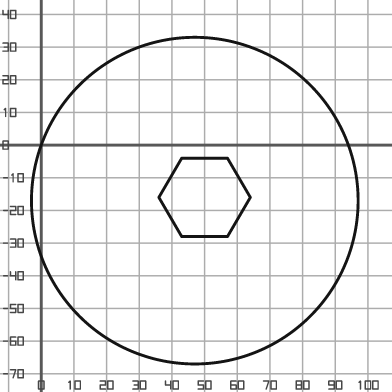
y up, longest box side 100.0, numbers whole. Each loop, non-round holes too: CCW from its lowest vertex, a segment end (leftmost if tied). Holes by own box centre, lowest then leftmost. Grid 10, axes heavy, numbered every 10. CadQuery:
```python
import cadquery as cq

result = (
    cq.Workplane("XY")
    .moveTo(47.0, -17.0)
    .circle(50.0)
    .moveTo(43.0, -28.0)
    .lineTo(57.0, -28.0)
    .lineTo(64.0, -16.0)
    .lineTo(57.0, -4.0)
    .lineTo(43.0, -4.0)
    .lineTo(36.0, -16.0)
    .close()
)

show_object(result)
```